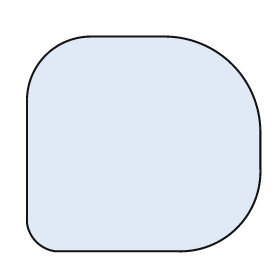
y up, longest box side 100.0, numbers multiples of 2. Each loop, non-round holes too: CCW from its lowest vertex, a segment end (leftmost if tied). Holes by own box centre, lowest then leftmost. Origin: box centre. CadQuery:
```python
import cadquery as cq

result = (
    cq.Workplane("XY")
    .moveTo(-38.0, -46.0)
    .lineTo(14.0, -46.0)
    .threePointArc((40.0, -36.0), (50.0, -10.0))
    .lineTo(50.0, 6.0)
    .threePointArc((38.0, 34.0), (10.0, 46.0))
    .lineTo(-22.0, 46.0)
    .threePointArc((-42.0, 38.0), (-50.0, 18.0))
    .lineTo(-50.0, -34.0)
    .threePointArc((-46.0, -42.0), (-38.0, -46.0))
    .close()
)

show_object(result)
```